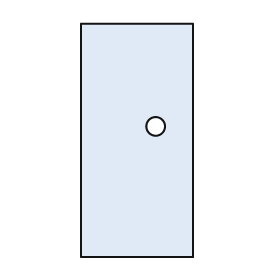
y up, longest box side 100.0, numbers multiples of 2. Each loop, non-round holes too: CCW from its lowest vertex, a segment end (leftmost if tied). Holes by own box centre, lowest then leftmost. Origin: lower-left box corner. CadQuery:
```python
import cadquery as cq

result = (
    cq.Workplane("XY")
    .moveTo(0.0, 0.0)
    .lineTo(48.0, 0.0)
    .lineTo(48.0, 100.0)
    .lineTo(0.0, 100.0)
    .close()
    .moveTo(32.0, 56.0)
    .circle(4.0)
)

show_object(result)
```